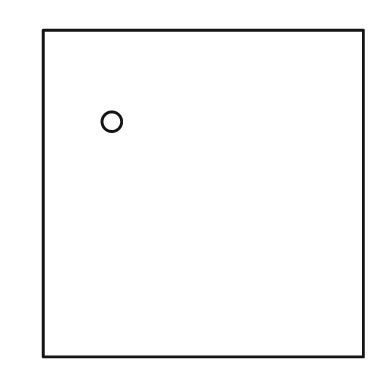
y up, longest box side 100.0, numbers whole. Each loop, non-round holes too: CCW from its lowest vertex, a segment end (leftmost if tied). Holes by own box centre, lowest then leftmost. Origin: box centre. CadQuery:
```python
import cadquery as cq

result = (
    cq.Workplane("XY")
    .moveTo(-49.0, -50.0)
    .lineTo(49.0, -50.0)
    .lineTo(49.0, 50.0)
    .lineTo(-49.0, 50.0)
    .close()
    .moveTo(-28.0, 22.0)
    .circle(3.0)
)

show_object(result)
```